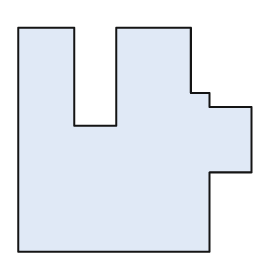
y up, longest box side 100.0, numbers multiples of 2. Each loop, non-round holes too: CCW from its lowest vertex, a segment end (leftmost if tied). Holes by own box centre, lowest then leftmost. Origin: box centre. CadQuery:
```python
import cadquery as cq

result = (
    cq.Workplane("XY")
    .moveTo(-50.0, -48.0)
    .lineTo(32.0, -48.0)
    .lineTo(32.0, -14.0)
    .lineTo(50.0, -14.0)
    .lineTo(50.0, 14.0)
    .lineTo(32.0, 14.0)
    .lineTo(32.0, 20.0)
    .lineTo(24.0, 20.0)
    .lineTo(24.0, 48.0)
    .lineTo(-8.0, 48.0)
    .lineTo(-8.0, 6.0)
    .lineTo(-26.0, 6.0)
    .lineTo(-26.0, 48.0)
    .lineTo(-50.0, 48.0)
    .close()
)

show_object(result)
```